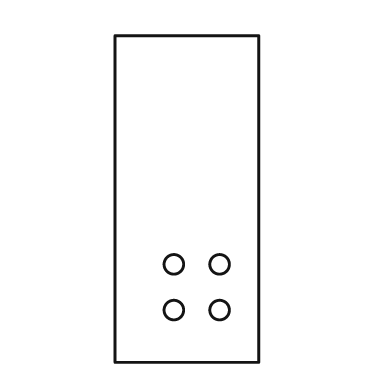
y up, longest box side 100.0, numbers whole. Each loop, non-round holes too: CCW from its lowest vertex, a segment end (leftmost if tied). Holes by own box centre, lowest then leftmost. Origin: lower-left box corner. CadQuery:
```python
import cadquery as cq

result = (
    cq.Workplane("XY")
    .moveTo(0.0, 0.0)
    .lineTo(44.0, 0.0)
    .lineTo(44.0, 100.0)
    .lineTo(0.0, 100.0)
    .close()
    .moveTo(18.0, 16.0)
    .circle(3.0)
    .moveTo(32.0, 16.0)
    .circle(3.0)
    .moveTo(18.0, 30.0)
    .circle(3.0)
    .moveTo(32.0, 30.0)
    .circle(3.0)
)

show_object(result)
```